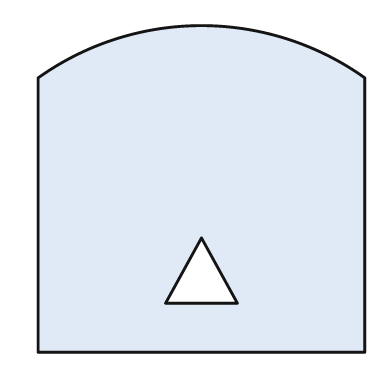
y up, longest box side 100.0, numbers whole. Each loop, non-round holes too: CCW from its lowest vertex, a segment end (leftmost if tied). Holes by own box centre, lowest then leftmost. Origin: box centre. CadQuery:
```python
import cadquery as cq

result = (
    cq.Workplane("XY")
    .moveTo(-50.0, -50.0)
    .lineTo(50.0, -50.0)
    .lineTo(50.0, 34.0)
    .threePointArc((0.0, 50.0), (-50.0, 34.0))
    .close()
    .moveTo(-11.0, -35.0)
    .lineTo(11.0, -35.0)
    .lineTo(0.0, -15.0)
    .close()
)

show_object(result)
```